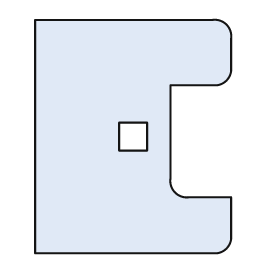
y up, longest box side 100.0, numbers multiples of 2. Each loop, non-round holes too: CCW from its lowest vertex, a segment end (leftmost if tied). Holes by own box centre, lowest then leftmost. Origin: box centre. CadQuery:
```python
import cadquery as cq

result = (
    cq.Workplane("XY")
    .moveTo(-42.0, -50.0)
    .lineTo(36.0, -50.0)
    .threePointArc((40.0, -48.0), (42.0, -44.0))
    .lineTo(42.0, -26.0)
    .lineTo(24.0, -26.0)
    .threePointArc((18.0, -24.0), (16.0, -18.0))
    .lineTo(16.0, 22.0)
    .lineTo(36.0, 22.0)
    .threePointArc((40.0, 24.0), (42.0, 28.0))
    .lineTo(42.0, 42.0)
    .threePointArc((40.0, 48.0), (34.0, 50.0))
    .lineTo(-42.0, 50.0)
    .close()
    .moveTo(-6.0, -6.0)
    .lineTo(6.0, -6.0)
    .lineTo(6.0, 6.0)
    .lineTo(-6.0, 6.0)
    .close()
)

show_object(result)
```